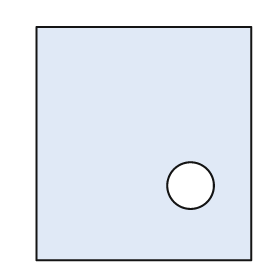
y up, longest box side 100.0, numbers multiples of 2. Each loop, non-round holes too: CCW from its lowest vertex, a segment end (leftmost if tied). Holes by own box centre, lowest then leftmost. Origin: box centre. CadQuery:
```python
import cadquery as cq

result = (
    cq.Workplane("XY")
    .moveTo(-46.0, -50.0)
    .lineTo(46.0, -50.0)
    .lineTo(46.0, 50.0)
    .lineTo(-46.0, 50.0)
    .close()
    .moveTo(20.0, -18.0)
    .circle(10.0)
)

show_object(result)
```